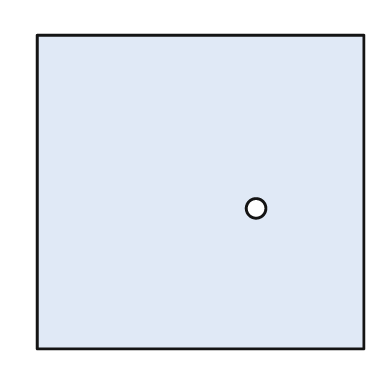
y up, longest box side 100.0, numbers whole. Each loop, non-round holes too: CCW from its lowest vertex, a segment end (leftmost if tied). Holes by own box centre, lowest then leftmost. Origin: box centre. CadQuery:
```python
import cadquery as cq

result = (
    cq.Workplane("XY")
    .moveTo(-50.0, -48.0)
    .lineTo(50.0, -48.0)
    .lineTo(50.0, 48.0)
    .lineTo(-50.0, 48.0)
    .close()
    .moveTo(17.0, -5.0)
    .circle(3.0)
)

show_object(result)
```